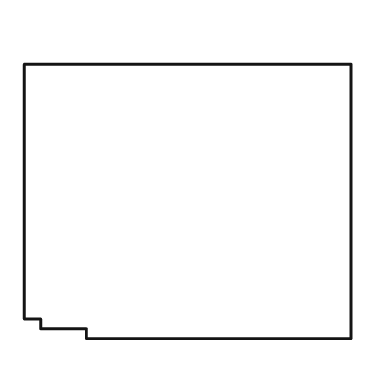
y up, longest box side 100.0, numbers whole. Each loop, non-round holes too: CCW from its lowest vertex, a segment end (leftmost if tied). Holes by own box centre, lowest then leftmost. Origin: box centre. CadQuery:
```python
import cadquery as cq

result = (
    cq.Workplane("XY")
    .moveTo(-31.0, -42.0)
    .lineTo(50.0, -42.0)
    .lineTo(50.0, 42.0)
    .lineTo(-50.0, 42.0)
    .lineTo(-50.0, -36.0)
    .lineTo(-45.0, -36.0)
    .lineTo(-45.0, -39.0)
    .lineTo(-31.0, -39.0)
    .close()
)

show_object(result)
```